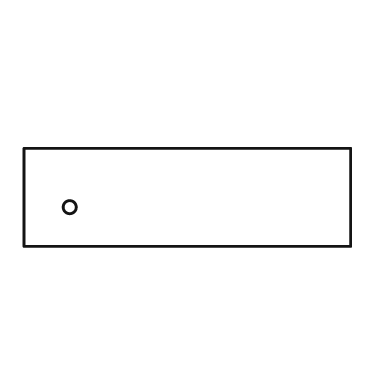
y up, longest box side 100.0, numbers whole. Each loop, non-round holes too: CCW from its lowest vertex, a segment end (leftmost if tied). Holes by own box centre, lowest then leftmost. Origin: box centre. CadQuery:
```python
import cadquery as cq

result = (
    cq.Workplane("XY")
    .moveTo(-50.0, -15.0)
    .lineTo(50.0, -15.0)
    .lineTo(50.0, 15.0)
    .lineTo(-50.0, 15.0)
    .close()
    .moveTo(-36.0, -3.0)
    .circle(2.0)
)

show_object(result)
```